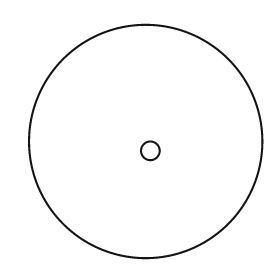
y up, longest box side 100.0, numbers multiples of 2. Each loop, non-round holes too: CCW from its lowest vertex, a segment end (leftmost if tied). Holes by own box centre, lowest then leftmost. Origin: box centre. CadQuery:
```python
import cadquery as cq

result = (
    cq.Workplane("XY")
    .moveTo(0.0, 0.0)
    .circle(50.0)
    .moveTo(2.0, -4.0)
    .circle(4.0)
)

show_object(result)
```